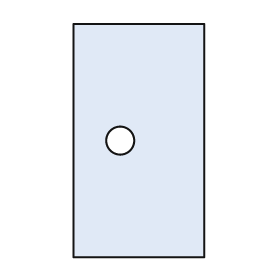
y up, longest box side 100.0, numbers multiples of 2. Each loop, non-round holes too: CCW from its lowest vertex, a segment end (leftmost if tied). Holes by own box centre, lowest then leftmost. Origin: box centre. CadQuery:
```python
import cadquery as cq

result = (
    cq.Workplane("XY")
    .moveTo(-28.0, -50.0)
    .lineTo(28.0, -50.0)
    .lineTo(28.0, 50.0)
    .lineTo(-28.0, 50.0)
    .close()
    .moveTo(-8.0, 0.0)
    .circle(6.0)
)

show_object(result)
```